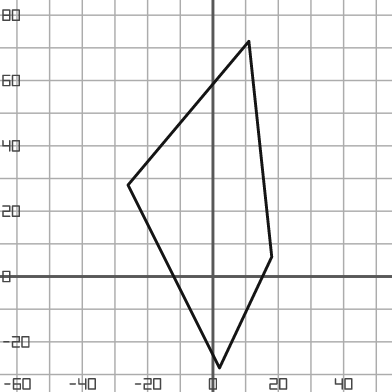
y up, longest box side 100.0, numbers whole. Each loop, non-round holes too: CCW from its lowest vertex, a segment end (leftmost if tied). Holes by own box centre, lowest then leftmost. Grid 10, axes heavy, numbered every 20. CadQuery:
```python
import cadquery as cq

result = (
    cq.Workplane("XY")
    .moveTo(2.0, -28.0)
    .lineTo(18.0, 6.0)
    .lineTo(11.0, 72.0)
    .lineTo(-26.0, 28.0)
    .close()
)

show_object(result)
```